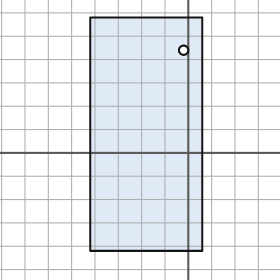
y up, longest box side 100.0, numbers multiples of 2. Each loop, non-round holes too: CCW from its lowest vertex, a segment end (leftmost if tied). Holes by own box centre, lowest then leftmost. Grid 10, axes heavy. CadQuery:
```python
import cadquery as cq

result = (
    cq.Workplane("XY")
    .moveTo(-42.0, -42.0)
    .lineTo(6.0, -42.0)
    .lineTo(6.0, 58.0)
    .lineTo(-42.0, 58.0)
    .close()
    .moveTo(-2.0, 44.0)
    .circle(2.0)
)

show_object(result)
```